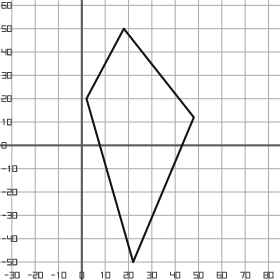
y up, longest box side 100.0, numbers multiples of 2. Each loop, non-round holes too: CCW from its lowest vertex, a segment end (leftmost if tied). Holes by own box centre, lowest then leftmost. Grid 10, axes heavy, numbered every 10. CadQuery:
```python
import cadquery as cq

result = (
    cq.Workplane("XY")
    .moveTo(22.0, -50.0)
    .lineTo(48.0, 12.0)
    .lineTo(18.0, 50.0)
    .lineTo(2.0, 20.0)
    .close()
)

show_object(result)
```